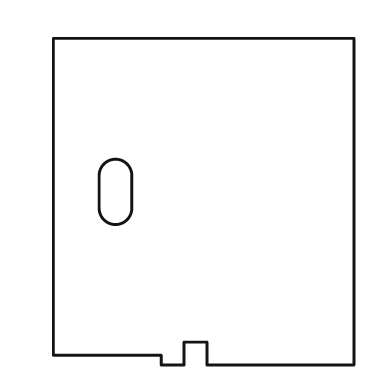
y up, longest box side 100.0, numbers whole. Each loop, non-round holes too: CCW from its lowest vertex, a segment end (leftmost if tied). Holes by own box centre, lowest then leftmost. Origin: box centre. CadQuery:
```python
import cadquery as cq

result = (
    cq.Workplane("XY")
    .moveTo(-13.0, -50.0)
    .lineTo(-6.0, -50.0)
    .lineTo(-6.0, -43.0)
    .lineTo(1.0, -43.0)
    .lineTo(1.0, -50.0)
    .lineTo(46.0, -50.0)
    .lineTo(46.0, 50.0)
    .lineTo(-46.0, 50.0)
    .lineTo(-46.0, -47.0)
    .lineTo(-13.0, -47.0)
    .close()
    .moveTo(-32.0, -2.0)
    .threePointArc((-27.0, -7.0), (-22.0, -2.0))
    .lineTo(-22.0, 8.0)
    .threePointArc((-27.0, 13.0), (-32.0, 8.0))
    .close()
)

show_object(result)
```